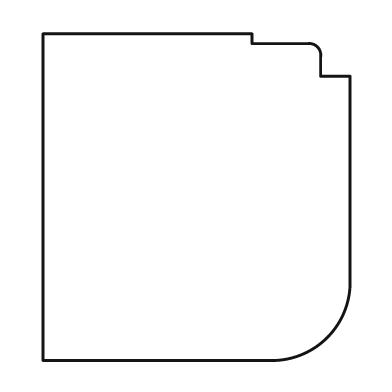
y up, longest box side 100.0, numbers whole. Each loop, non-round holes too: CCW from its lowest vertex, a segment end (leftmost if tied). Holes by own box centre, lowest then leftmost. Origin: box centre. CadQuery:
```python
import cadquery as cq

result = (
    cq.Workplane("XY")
    .moveTo(-47.0, -50.0)
    .lineTo(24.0, -50.0)
    .threePointArc((40.0, -43.0), (47.0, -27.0))
    .lineTo(47.0, 37.0)
    .lineTo(38.0, 37.0)
    .lineTo(38.0, 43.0)
    .threePointArc((37.0, 46.0), (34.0, 47.0))
    .lineTo(17.0, 47.0)
    .lineTo(17.0, 50.0)
    .lineTo(-47.0, 50.0)
    .close()
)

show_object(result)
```